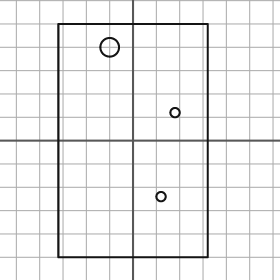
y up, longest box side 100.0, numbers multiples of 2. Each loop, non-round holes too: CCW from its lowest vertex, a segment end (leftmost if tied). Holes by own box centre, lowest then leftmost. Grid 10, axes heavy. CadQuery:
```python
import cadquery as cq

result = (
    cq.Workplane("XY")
    .moveTo(-32.0, -50.0)
    .lineTo(32.0, -50.0)
    .lineTo(32.0, 50.0)
    .lineTo(-32.0, 50.0)
    .close()
    .moveTo(12.0, -24.0)
    .circle(2.0)
    .moveTo(18.0, 12.0)
    .circle(2.0)
    .moveTo(-10.0, 40.0)
    .circle(4.0)
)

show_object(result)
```